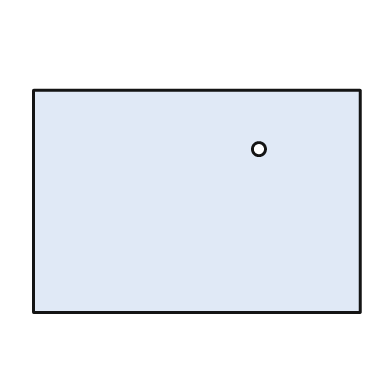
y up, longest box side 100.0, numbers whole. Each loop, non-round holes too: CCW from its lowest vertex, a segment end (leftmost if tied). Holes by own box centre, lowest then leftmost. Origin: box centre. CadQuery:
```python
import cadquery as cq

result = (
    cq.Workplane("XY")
    .moveTo(-50.0, -34.0)
    .lineTo(50.0, -34.0)
    .lineTo(50.0, 34.0)
    .lineTo(-50.0, 34.0)
    .close()
    .moveTo(19.0, 16.0)
    .circle(2.0)
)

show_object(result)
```